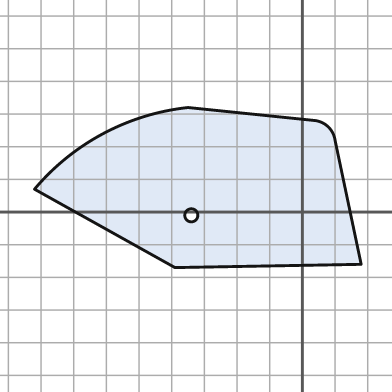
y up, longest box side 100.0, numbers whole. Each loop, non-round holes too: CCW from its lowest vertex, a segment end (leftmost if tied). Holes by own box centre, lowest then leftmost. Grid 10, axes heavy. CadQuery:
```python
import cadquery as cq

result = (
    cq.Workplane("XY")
    .moveTo(-39.0, -17.0)
    .lineTo(18.0, -16.0)
    .lineTo(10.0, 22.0)
    .threePointArc((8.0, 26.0), (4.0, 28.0))
    .lineTo(-35.0, 32.0)
    .threePointArc((-61.0, 24.0), (-82.0, 7.0))
    .close()
    .moveTo(-34.0, -1.0)
    .circle(2.0)
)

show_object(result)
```